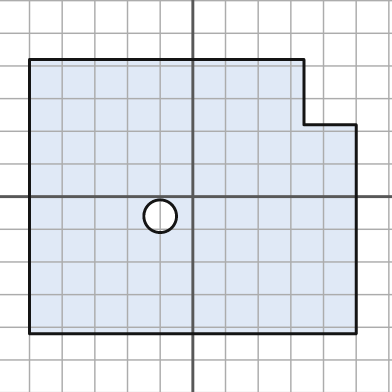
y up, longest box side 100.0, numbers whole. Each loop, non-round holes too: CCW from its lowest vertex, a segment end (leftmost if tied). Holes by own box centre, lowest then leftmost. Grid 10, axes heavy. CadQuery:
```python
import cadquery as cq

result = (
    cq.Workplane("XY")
    .moveTo(-50.0, -42.0)
    .lineTo(50.0, -42.0)
    .lineTo(50.0, 22.0)
    .lineTo(34.0, 22.0)
    .lineTo(34.0, 42.0)
    .lineTo(-50.0, 42.0)
    .close()
    .moveTo(-10.0, -6.0)
    .circle(5.0)
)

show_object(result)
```